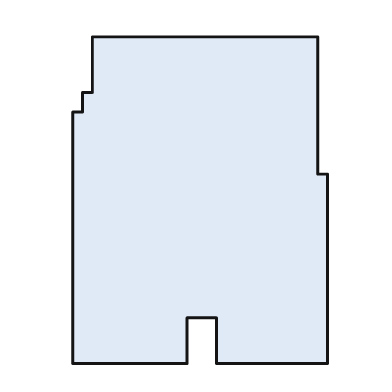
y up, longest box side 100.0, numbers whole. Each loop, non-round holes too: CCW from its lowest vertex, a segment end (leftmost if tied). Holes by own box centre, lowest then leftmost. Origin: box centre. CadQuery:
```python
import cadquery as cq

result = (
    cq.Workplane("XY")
    .moveTo(-39.0, -50.0)
    .lineTo(-4.0, -50.0)
    .lineTo(-4.0, -36.0)
    .lineTo(5.0, -36.0)
    .lineTo(5.0, -50.0)
    .lineTo(39.0, -50.0)
    .lineTo(39.0, 8.0)
    .lineTo(36.0, 8.0)
    .lineTo(36.0, 50.0)
    .lineTo(-33.0, 50.0)
    .lineTo(-33.0, 33.0)
    .lineTo(-36.0, 33.0)
    .lineTo(-36.0, 27.0)
    .lineTo(-39.0, 27.0)
    .close()
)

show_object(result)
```